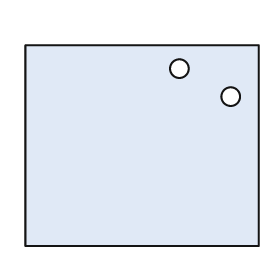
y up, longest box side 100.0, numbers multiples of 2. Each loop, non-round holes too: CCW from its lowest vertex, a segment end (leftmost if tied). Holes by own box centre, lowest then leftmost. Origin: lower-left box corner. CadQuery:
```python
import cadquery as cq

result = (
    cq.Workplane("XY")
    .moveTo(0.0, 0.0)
    .lineTo(100.0, 0.0)
    .lineTo(100.0, 86.0)
    .lineTo(0.0, 86.0)
    .close()
    .moveTo(88.0, 64.0)
    .circle(4.0)
    .moveTo(66.0, 76.0)
    .circle(4.0)
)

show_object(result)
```